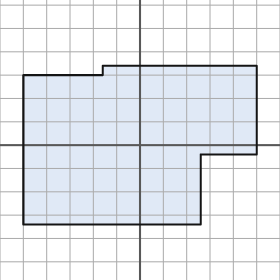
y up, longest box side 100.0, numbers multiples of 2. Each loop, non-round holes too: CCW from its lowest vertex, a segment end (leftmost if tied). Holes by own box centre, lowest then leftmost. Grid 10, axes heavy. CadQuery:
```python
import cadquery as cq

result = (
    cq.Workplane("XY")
    .moveTo(-50.0, -34.0)
    .lineTo(26.0, -34.0)
    .lineTo(26.0, -4.0)
    .lineTo(50.0, -4.0)
    .lineTo(50.0, 34.0)
    .lineTo(-16.0, 34.0)
    .lineTo(-16.0, 30.0)
    .lineTo(-50.0, 30.0)
    .close()
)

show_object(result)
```